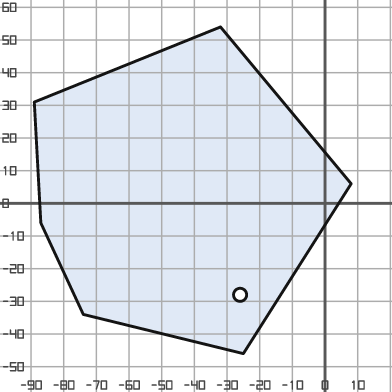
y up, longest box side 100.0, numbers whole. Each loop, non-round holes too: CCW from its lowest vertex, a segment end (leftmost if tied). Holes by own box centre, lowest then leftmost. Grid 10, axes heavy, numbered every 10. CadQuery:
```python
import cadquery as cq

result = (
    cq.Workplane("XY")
    .moveTo(-25.0, -46.0)
    .lineTo(8.0, 6.0)
    .lineTo(-32.0, 54.0)
    .lineTo(-89.0, 31.0)
    .lineTo(-87.0, -6.0)
    .lineTo(-74.0, -34.0)
    .close()
    .moveTo(-26.0, -28.0)
    .circle(2.0)
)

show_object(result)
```